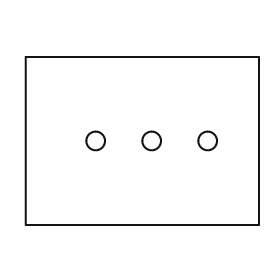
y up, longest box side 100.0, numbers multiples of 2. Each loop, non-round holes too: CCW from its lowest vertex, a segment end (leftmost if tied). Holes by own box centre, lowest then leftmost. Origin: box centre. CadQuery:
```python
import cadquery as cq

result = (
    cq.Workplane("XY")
    .moveTo(-50.0, -36.0)
    .lineTo(50.0, -36.0)
    .lineTo(50.0, 36.0)
    .lineTo(-50.0, 36.0)
    .close()
    .moveTo(-20.0, 0.0)
    .circle(4.0)
    .moveTo(4.0, 0.0)
    .circle(4.0)
    .moveTo(28.0, 0.0)
    .circle(4.0)
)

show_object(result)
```